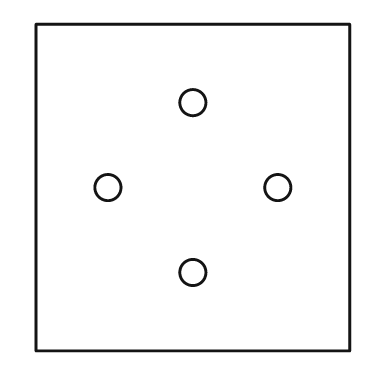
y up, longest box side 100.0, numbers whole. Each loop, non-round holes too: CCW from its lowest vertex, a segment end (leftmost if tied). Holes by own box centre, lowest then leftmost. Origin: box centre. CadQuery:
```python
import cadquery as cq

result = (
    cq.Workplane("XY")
    .moveTo(-48.0, -50.0)
    .lineTo(48.0, -50.0)
    .lineTo(48.0, 50.0)
    .lineTo(-48.0, 50.0)
    .close()
    .moveTo(0.0, -26.0)
    .circle(4.0)
    .moveTo(-26.0, 0.0)
    .circle(4.0)
    .moveTo(26.0, 0.0)
    .circle(4.0)
    .moveTo(0.0, 26.0)
    .circle(4.0)
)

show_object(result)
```